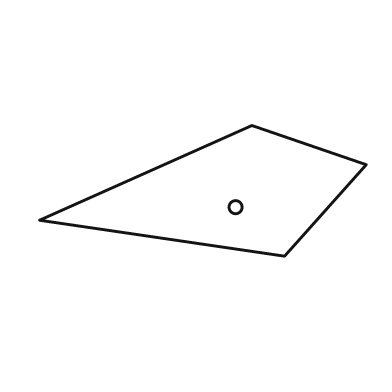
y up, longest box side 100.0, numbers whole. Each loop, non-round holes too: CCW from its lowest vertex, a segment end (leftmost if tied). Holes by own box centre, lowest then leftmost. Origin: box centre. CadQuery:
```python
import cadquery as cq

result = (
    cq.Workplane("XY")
    .moveTo(25.0, -20.0)
    .lineTo(50.0, 8.0)
    .lineTo(15.0, 20.0)
    .lineTo(-50.0, -9.0)
    .close()
    .moveTo(10.0, -5.0)
    .circle(2.0)
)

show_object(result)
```